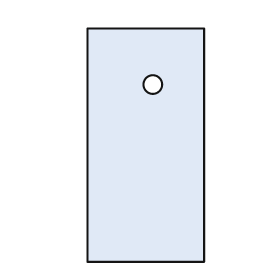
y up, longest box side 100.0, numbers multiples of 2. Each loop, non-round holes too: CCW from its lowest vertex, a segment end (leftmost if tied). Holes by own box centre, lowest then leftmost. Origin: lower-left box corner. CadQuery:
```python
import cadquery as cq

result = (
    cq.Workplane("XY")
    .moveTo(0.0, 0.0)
    .lineTo(50.0, 0.0)
    .lineTo(50.0, 100.0)
    .lineTo(0.0, 100.0)
    .close()
    .moveTo(28.0, 76.0)
    .circle(4.0)
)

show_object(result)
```